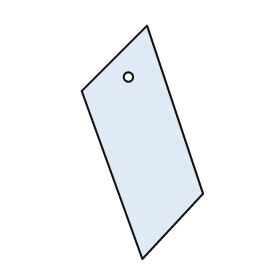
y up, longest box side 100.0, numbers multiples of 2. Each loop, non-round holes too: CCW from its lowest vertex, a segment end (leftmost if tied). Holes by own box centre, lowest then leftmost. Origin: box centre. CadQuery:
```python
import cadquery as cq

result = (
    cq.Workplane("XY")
    .moveTo(0.0, -50.0)
    .lineTo(26.0, -22.0)
    .lineTo(2.0, 50.0)
    .lineTo(-26.0, 22.0)
    .close()
    .moveTo(-6.0, 28.0)
    .circle(2.0)
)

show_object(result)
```